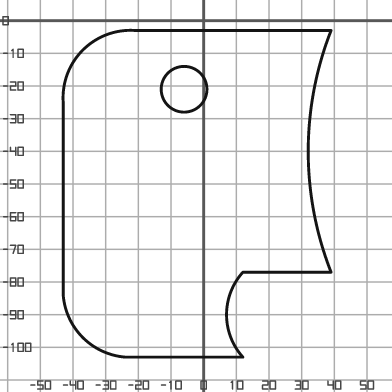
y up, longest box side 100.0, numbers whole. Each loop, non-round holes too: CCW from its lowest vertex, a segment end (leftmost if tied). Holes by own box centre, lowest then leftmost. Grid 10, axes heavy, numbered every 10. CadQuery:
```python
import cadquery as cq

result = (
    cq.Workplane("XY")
    .moveTo(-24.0, -103.0)
    .lineTo(12.0, -103.0)
    .threePointArc((7.0, -90.0), (12.0, -77.0))
    .lineTo(39.0, -77.0)
    .threePointArc((32.0, -40.0), (39.0, -3.0))
    .lineTo(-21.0, -3.0)
    .threePointArc((-37.0, -9.0), (-43.0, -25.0))
    .lineTo(-43.0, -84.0)
    .threePointArc((-37.0, -97.0), (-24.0, -103.0))
    .close()
    .moveTo(-6.0, -21.0)
    .circle(7.0)
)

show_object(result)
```